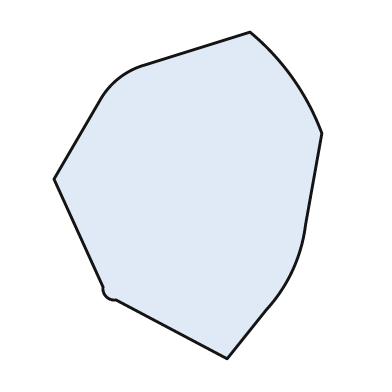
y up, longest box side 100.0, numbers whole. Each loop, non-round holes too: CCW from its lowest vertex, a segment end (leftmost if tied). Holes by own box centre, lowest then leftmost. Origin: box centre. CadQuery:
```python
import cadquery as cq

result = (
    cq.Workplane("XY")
    .moveTo(12.0, -50.0)
    .lineTo(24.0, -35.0)
    .threePointArc((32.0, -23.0), (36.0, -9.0))
    .lineTo(41.0, 19.0)
    .threePointArc((32.0, 36.0), (19.0, 50.0))
    .lineTo(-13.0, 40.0)
    .threePointArc((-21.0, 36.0), (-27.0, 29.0))
    .lineTo(-41.0, 5.0)
    .lineTo(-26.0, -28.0)
    .threePointArc((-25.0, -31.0), (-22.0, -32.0))
    .close()
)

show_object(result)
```